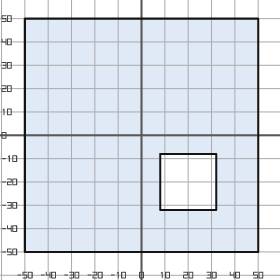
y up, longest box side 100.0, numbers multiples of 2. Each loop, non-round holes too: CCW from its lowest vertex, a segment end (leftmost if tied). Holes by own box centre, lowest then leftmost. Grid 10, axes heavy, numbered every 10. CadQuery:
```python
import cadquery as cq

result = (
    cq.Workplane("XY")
    .moveTo(-50.0, -50.0)
    .lineTo(50.0, -50.0)
    .lineTo(50.0, 50.0)
    .lineTo(-50.0, 50.0)
    .close()
    .moveTo(8.0, -32.0)
    .lineTo(32.0, -32.0)
    .lineTo(32.0, -8.0)
    .lineTo(8.0, -8.0)
    .close()
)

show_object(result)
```